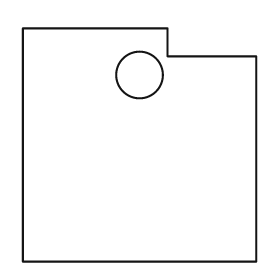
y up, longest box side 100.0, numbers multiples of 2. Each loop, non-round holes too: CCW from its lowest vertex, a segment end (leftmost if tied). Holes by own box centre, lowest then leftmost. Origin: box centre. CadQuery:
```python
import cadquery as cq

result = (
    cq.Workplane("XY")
    .moveTo(-50.0, -50.0)
    .lineTo(50.0, -50.0)
    .lineTo(50.0, 38.0)
    .lineTo(12.0, 38.0)
    .lineTo(12.0, 50.0)
    .lineTo(-50.0, 50.0)
    .close()
    .moveTo(0.0, 30.0)
    .circle(10.0)
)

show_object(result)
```